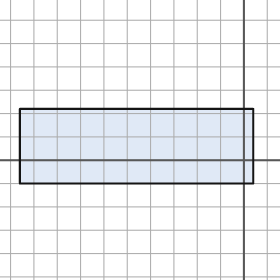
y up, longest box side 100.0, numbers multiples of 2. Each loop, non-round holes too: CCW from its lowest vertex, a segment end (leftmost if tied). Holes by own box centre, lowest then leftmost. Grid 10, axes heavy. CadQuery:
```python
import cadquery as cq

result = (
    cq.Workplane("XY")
    .moveTo(-96.0, -10.0)
    .lineTo(4.0, -10.0)
    .lineTo(4.0, 22.0)
    .lineTo(-96.0, 22.0)
    .close()
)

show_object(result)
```